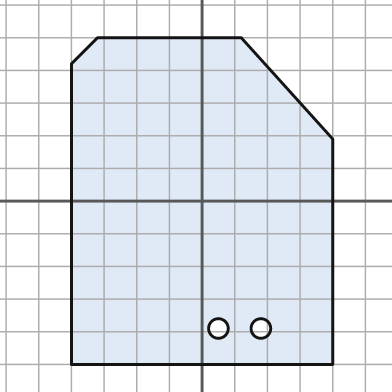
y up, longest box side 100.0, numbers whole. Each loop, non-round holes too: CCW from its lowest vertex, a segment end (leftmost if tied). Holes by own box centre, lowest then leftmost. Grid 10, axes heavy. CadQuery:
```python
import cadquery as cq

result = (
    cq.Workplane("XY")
    .moveTo(-40.0, -50.0)
    .lineTo(40.0, -50.0)
    .lineTo(40.0, 19.0)
    .lineTo(12.0, 50.0)
    .lineTo(-32.0, 50.0)
    .lineTo(-40.0, 42.0)
    .close()
    .moveTo(5.0, -39.0)
    .circle(3.0)
    .moveTo(18.0, -39.0)
    .circle(3.0)
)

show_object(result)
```